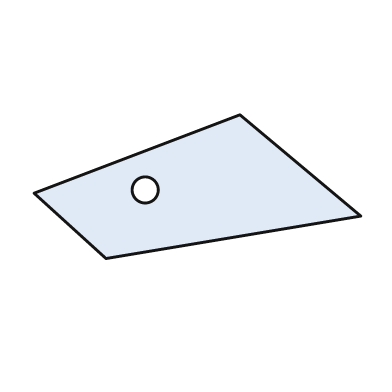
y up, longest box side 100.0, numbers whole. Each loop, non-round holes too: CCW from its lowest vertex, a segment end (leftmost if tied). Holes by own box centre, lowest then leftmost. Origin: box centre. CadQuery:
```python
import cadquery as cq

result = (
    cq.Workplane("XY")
    .moveTo(-28.0, -22.0)
    .lineTo(50.0, -9.0)
    .lineTo(13.0, 22.0)
    .lineTo(-50.0, -2.0)
    .close()
    .moveTo(-16.0, -1.0)
    .circle(4.0)
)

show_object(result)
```